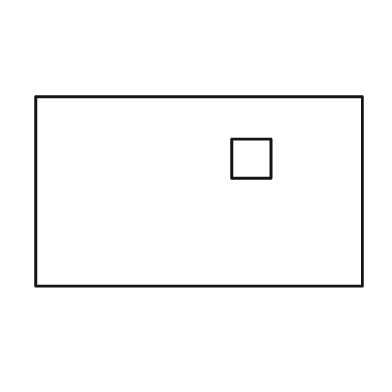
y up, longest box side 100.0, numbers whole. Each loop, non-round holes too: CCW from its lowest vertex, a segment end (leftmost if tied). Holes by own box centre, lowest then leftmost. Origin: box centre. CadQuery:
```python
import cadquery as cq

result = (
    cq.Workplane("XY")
    .moveTo(-50.0, -29.0)
    .lineTo(50.0, -29.0)
    .lineTo(50.0, 29.0)
    .lineTo(-50.0, 29.0)
    .close()
    .moveTo(10.0, 4.0)
    .lineTo(22.0, 4.0)
    .lineTo(22.0, 16.0)
    .lineTo(10.0, 16.0)
    .close()
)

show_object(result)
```